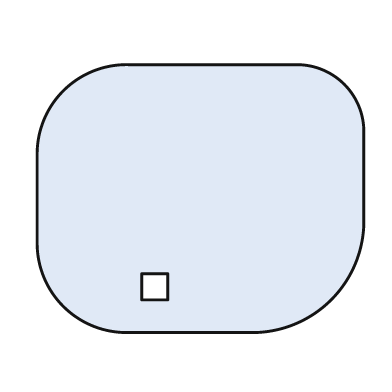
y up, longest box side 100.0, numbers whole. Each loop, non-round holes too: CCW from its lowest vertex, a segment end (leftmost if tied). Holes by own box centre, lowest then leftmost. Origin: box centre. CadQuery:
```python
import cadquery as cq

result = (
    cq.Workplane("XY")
    .moveTo(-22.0, -41.0)
    .lineTo(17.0, -41.0)
    .threePointArc((40.0, -31.0), (50.0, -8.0))
    .lineTo(50.0, 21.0)
    .threePointArc((44.0, 35.0), (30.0, 41.0))
    .lineTo(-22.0, 41.0)
    .threePointArc((-42.0, 33.0), (-50.0, 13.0))
    .lineTo(-50.0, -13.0)
    .threePointArc((-42.0, -33.0), (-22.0, -41.0))
    .close()
    .moveTo(-18.0, -31.0)
    .lineTo(-10.0, -31.0)
    .lineTo(-10.0, -23.0)
    .lineTo(-18.0, -23.0)
    .close()
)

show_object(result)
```